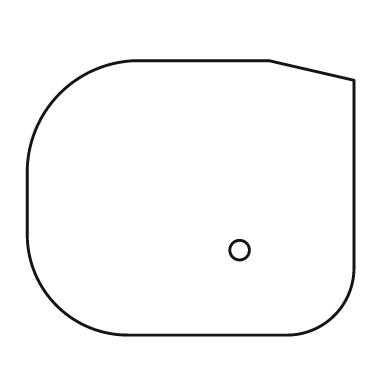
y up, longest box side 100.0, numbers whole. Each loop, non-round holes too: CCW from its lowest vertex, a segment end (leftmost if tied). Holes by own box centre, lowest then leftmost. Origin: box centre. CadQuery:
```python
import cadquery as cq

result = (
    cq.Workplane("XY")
    .moveTo(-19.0, -42.0)
    .lineTo(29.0, -42.0)
    .threePointArc((44.0, -36.0), (50.0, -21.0))
    .lineTo(50.0, 36.0)
    .lineTo(24.0, 42.0)
    .lineTo(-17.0, 42.0)
    .threePointArc((-40.0, 32.0), (-50.0, 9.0))
    .lineTo(-50.0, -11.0)
    .threePointArc((-41.0, -33.0), (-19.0, -42.0))
    .close()
    .moveTo(15.0, -16.0)
    .circle(3.0)
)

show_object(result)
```